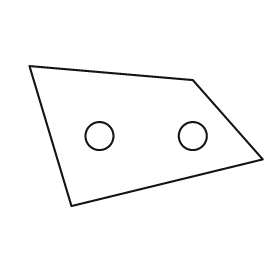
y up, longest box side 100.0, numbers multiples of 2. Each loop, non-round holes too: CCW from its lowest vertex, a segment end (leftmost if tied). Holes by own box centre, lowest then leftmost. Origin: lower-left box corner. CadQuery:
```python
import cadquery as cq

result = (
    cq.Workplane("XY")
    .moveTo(18.0, 0.0)
    .lineTo(100.0, 20.0)
    .lineTo(70.0, 54.0)
    .lineTo(0.0, 60.0)
    .close()
    .moveTo(30.0, 30.0)
    .circle(6.0)
    .moveTo(70.0, 30.0)
    .circle(6.0)
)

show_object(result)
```